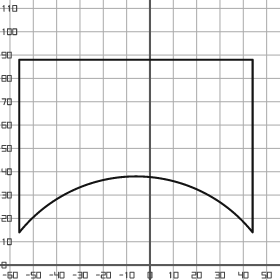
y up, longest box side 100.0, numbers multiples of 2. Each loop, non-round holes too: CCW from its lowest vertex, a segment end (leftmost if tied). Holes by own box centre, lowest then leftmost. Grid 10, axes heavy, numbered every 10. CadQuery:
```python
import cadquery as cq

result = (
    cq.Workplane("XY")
    .moveTo(-56.0, 14.0)
    .threePointArc((-6.0, 38.0), (44.0, 14.0))
    .lineTo(44.0, 88.0)
    .lineTo(-56.0, 88.0)
    .close()
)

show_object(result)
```